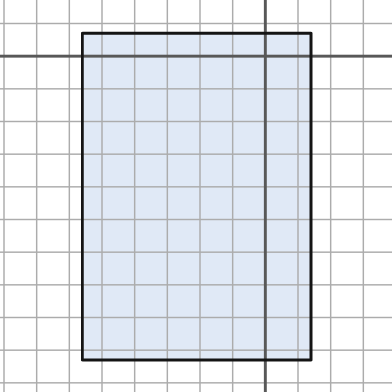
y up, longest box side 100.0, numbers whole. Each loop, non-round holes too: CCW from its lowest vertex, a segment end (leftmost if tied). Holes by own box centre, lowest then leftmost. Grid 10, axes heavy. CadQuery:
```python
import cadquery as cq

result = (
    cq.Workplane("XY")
    .moveTo(-56.0, -93.0)
    .lineTo(14.0, -93.0)
    .lineTo(14.0, 7.0)
    .lineTo(-56.0, 7.0)
    .close()
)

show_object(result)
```